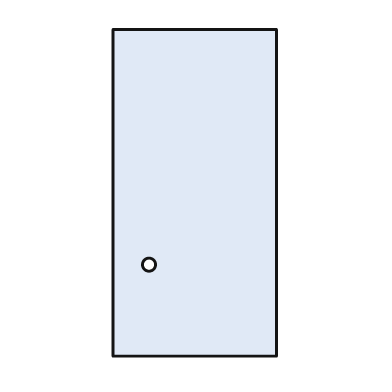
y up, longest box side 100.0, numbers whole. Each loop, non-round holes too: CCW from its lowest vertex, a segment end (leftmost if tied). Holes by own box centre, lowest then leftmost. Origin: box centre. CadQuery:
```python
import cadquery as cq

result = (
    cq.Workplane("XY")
    .moveTo(-25.0, -50.0)
    .lineTo(25.0, -50.0)
    .lineTo(25.0, 50.0)
    .lineTo(-25.0, 50.0)
    .close()
    .moveTo(-14.0, -22.0)
    .circle(2.0)
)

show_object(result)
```